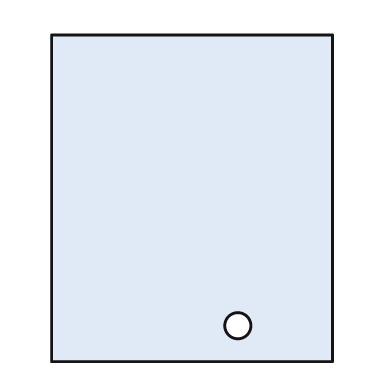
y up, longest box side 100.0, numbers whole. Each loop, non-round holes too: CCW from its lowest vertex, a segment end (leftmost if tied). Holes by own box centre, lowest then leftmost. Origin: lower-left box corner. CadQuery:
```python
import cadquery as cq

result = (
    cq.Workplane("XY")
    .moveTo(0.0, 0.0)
    .lineTo(86.0, 0.0)
    .lineTo(86.0, 100.0)
    .lineTo(0.0, 100.0)
    .close()
    .moveTo(57.0, 11.0)
    .circle(4.0)
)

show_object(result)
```